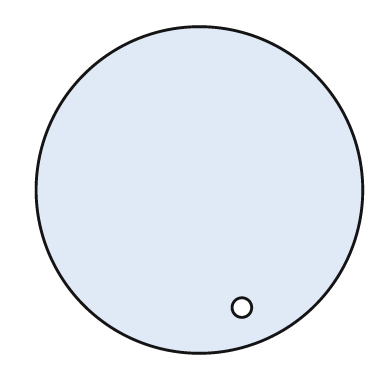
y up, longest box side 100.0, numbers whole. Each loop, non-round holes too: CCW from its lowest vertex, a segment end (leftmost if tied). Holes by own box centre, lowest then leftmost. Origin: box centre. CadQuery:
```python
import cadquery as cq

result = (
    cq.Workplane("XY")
    .moveTo(0.0, 0.0)
    .circle(50.0)
    .moveTo(13.0, -36.0)
    .circle(3.0)
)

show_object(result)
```